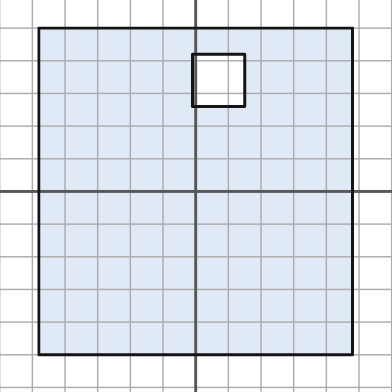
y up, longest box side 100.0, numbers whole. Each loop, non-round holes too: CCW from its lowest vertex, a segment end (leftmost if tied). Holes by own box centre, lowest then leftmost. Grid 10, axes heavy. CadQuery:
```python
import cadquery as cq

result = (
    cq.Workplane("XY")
    .moveTo(-48.0, -50.0)
    .lineTo(48.0, -50.0)
    .lineTo(48.0, 50.0)
    .lineTo(-48.0, 50.0)
    .close()
    .moveTo(-1.0, 26.0)
    .lineTo(15.0, 26.0)
    .lineTo(15.0, 42.0)
    .lineTo(-1.0, 42.0)
    .close()
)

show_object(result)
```